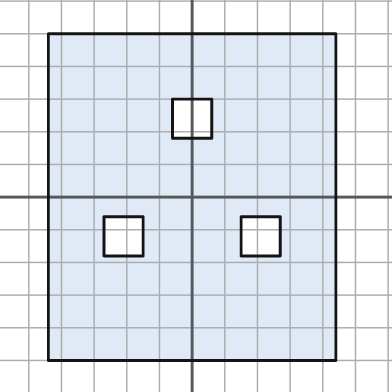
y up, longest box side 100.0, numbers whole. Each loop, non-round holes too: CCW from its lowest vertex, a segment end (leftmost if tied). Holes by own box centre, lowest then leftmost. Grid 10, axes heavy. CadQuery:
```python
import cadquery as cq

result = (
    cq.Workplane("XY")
    .moveTo(-44.0, -50.0)
    .lineTo(44.0, -50.0)
    .lineTo(44.0, 50.0)
    .lineTo(-44.0, 50.0)
    .close()
    .moveTo(-27.0, -18.0)
    .lineTo(-15.0, -18.0)
    .lineTo(-15.0, -6.0)
    .lineTo(-27.0, -6.0)
    .close()
    .moveTo(15.0, -18.0)
    .lineTo(27.0, -18.0)
    .lineTo(27.0, -6.0)
    .lineTo(15.0, -6.0)
    .close()
    .moveTo(-6.0, 18.0)
    .lineTo(6.0, 18.0)
    .lineTo(6.0, 30.0)
    .lineTo(-6.0, 30.0)
    .close()
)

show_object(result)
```